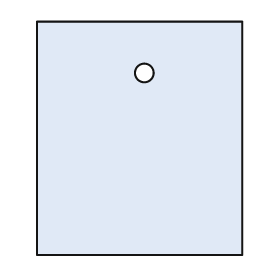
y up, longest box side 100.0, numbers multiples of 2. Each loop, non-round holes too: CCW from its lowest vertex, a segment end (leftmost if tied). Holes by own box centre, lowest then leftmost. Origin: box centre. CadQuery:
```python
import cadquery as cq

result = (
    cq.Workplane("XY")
    .moveTo(-44.0, -50.0)
    .lineTo(44.0, -50.0)
    .lineTo(44.0, 50.0)
    .lineTo(-44.0, 50.0)
    .close()
    .moveTo(2.0, 28.0)
    .circle(4.0)
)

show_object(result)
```